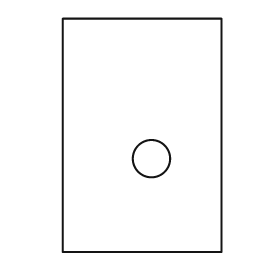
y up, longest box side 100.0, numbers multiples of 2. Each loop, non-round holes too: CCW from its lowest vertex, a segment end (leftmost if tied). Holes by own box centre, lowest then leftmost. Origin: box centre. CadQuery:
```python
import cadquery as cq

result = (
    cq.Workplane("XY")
    .moveTo(-34.0, -50.0)
    .lineTo(34.0, -50.0)
    .lineTo(34.0, 50.0)
    .lineTo(-34.0, 50.0)
    .close()
    .moveTo(4.0, -10.0)
    .circle(8.0)
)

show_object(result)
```